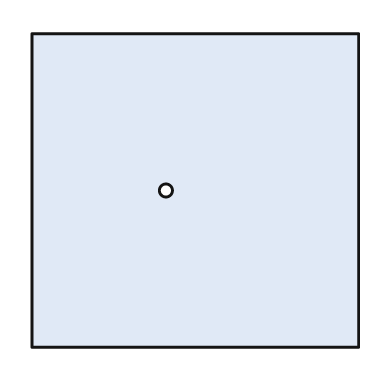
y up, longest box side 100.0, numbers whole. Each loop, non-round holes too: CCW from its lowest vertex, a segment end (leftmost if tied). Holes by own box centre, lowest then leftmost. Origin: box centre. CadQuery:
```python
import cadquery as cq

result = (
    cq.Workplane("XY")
    .moveTo(-50.0, -48.0)
    .lineTo(50.0, -48.0)
    .lineTo(50.0, 48.0)
    .lineTo(-50.0, 48.0)
    .close()
    .moveTo(-9.0, 0.0)
    .circle(2.0)
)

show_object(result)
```